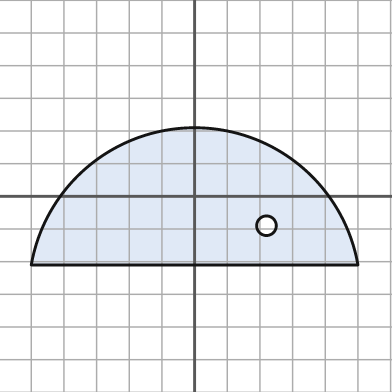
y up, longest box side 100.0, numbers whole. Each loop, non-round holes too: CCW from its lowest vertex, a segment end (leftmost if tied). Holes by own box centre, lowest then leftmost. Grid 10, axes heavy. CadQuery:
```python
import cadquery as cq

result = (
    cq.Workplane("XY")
    .moveTo(-50.0, -21.0)
    .lineTo(50.0, -21.0)
    .threePointArc((0.0, 21.0), (-50.0, -21.0))
    .close()
    .moveTo(22.0, -9.0)
    .circle(3.0)
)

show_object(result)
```